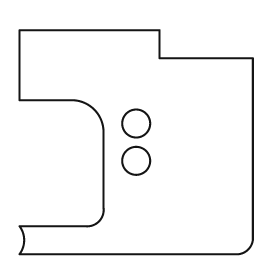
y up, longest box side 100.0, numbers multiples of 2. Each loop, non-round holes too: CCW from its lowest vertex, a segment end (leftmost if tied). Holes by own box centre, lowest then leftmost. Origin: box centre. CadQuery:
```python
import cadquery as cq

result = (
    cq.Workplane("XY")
    .moveTo(-50.0, -48.0)
    .lineTo(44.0, -48.0)
    .threePointArc((48.0, -46.0), (50.0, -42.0))
    .lineTo(50.0, 36.0)
    .lineTo(10.0, 36.0)
    .lineTo(10.0, 48.0)
    .lineTo(-50.0, 48.0)
    .lineTo(-50.0, 18.0)
    .lineTo(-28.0, 18.0)
    .threePointArc((-18.0, 14.0), (-14.0, 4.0))
    .lineTo(-14.0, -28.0)
    .threePointArc((-16.0, -34.0), (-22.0, -36.0))
    .lineTo(-50.0, -36.0)
    .threePointArc((-48.0, -42.0), (-50.0, -48.0))
    .close()
    .moveTo(0.0, -8.0)
    .circle(6.0)
    .moveTo(0.0, 8.0)
    .circle(6.0)
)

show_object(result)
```